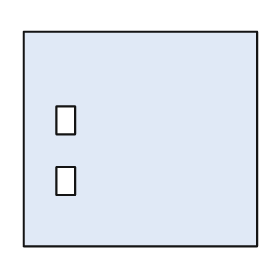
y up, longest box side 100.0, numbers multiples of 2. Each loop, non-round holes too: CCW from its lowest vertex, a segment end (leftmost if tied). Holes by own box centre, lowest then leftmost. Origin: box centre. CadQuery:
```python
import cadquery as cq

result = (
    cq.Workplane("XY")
    .moveTo(-50.0, -46.0)
    .lineTo(50.0, -46.0)
    .lineTo(50.0, 46.0)
    .lineTo(-50.0, 46.0)
    .close()
    .moveTo(-36.0, -24.0)
    .lineTo(-28.0, -24.0)
    .lineTo(-28.0, -12.0)
    .lineTo(-36.0, -12.0)
    .close()
    .moveTo(-36.0, 2.0)
    .lineTo(-28.0, 2.0)
    .lineTo(-28.0, 14.0)
    .lineTo(-36.0, 14.0)
    .close()
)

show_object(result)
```